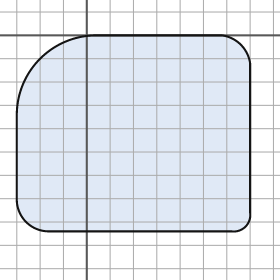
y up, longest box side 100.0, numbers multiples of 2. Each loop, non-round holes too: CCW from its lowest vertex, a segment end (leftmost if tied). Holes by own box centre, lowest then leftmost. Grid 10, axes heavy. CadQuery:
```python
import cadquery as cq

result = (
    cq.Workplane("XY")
    .moveTo(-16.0, -84.0)
    .lineTo(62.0, -84.0)
    .threePointArc((68.0, -82.0), (70.0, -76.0))
    .lineTo(70.0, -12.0)
    .threePointArc((66.0, -4.0), (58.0, 0.0))
    .lineTo(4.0, 0.0)
    .threePointArc((-20.0, -10.0), (-30.0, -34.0))
    .lineTo(-30.0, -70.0)
    .threePointArc((-26.0, -80.0), (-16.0, -84.0))
    .close()
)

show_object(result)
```